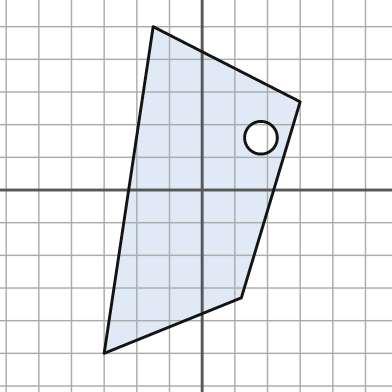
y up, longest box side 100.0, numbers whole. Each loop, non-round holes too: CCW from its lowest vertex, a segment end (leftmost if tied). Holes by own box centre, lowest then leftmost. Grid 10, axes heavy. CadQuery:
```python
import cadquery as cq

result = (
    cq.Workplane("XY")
    .moveTo(-30.0, -50.0)
    .lineTo(12.0, -33.0)
    .lineTo(30.0, 27.0)
    .lineTo(-15.0, 50.0)
    .close()
    .moveTo(18.0, 16.0)
    .circle(5.0)
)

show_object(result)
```